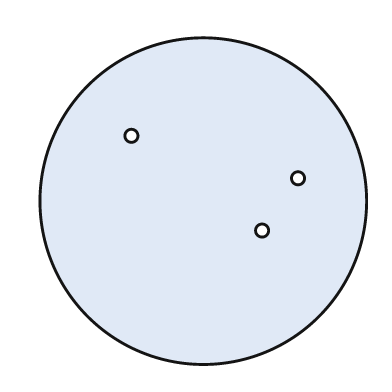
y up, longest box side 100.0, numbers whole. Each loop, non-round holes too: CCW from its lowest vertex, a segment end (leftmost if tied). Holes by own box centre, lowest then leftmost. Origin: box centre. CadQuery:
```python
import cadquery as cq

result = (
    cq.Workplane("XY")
    .moveTo(0.0, 0.0)
    .circle(50.0)
    .moveTo(18.0, -9.0)
    .circle(2.0)
    .moveTo(29.0, 7.0)
    .circle(2.0)
    .moveTo(-22.0, 20.0)
    .circle(2.0)
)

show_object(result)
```